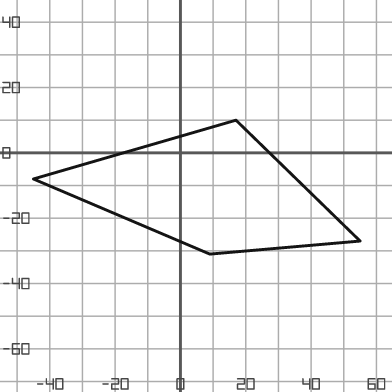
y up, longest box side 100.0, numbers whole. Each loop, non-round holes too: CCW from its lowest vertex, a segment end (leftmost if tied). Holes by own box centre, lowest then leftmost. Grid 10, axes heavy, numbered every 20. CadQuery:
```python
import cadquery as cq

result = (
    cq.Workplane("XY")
    .moveTo(9.0, -31.0)
    .lineTo(55.0, -27.0)
    .lineTo(17.0, 10.0)
    .lineTo(-45.0, -8.0)
    .close()
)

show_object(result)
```